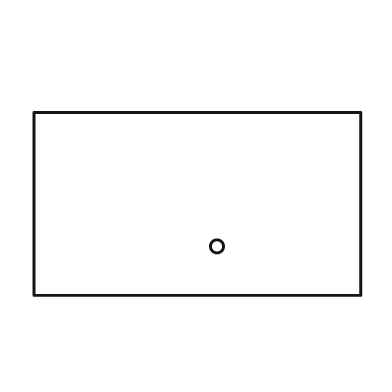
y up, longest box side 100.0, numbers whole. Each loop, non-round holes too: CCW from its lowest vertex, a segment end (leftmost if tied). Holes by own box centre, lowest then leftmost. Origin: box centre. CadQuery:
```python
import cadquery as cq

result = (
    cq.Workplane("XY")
    .moveTo(-50.0, -28.0)
    .lineTo(50.0, -28.0)
    .lineTo(50.0, 28.0)
    .lineTo(-50.0, 28.0)
    .close()
    .moveTo(6.0, -13.0)
    .circle(2.0)
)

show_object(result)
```